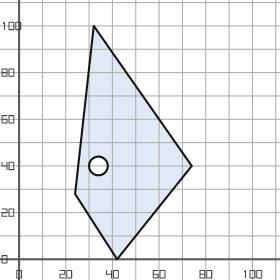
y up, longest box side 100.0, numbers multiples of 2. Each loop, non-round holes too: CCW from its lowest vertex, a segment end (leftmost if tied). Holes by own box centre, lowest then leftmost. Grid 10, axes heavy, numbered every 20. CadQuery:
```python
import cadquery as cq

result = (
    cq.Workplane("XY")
    .moveTo(42.0, 0.0)
    .lineTo(74.0, 40.0)
    .lineTo(32.0, 100.0)
    .lineTo(24.0, 28.0)
    .close()
    .moveTo(34.0, 40.0)
    .circle(4.0)
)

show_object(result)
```